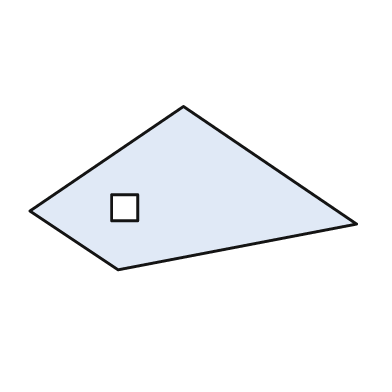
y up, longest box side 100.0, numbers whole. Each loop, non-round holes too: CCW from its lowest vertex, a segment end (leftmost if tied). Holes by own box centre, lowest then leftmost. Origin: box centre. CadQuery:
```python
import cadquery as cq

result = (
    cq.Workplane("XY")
    .moveTo(-23.0, -25.0)
    .lineTo(50.0, -11.0)
    .lineTo(-3.0, 25.0)
    .lineTo(-50.0, -7.0)
    .close()
    .moveTo(-25.0, -10.0)
    .lineTo(-17.0, -10.0)
    .lineTo(-17.0, -2.0)
    .lineTo(-25.0, -2.0)
    .close()
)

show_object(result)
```